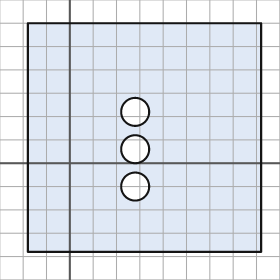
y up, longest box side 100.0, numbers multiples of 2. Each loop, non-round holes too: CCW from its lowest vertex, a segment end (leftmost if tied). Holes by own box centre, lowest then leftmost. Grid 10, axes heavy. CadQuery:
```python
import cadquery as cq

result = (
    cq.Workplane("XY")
    .moveTo(-18.0, -38.0)
    .lineTo(82.0, -38.0)
    .lineTo(82.0, 60.0)
    .lineTo(-18.0, 60.0)
    .close()
    .moveTo(28.0, -10.0)
    .circle(6.0)
    .moveTo(28.0, 6.0)
    .circle(6.0)
    .moveTo(28.0, 22.0)
    .circle(6.0)
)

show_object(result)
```